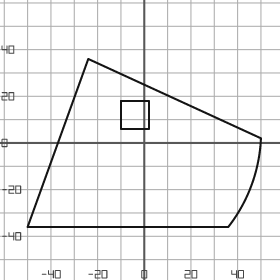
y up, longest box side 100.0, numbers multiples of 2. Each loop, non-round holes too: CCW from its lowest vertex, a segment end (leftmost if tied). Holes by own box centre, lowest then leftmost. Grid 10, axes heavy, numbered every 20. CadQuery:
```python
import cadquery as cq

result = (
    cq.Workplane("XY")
    .moveTo(-50.0, -36.0)
    .lineTo(36.0, -36.0)
    .threePointArc((46.0, -18.0), (50.0, 2.0))
    .lineTo(-24.0, 36.0)
    .close()
    .moveTo(-10.0, 6.0)
    .lineTo(2.0, 6.0)
    .lineTo(2.0, 18.0)
    .lineTo(-10.0, 18.0)
    .close()
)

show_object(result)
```